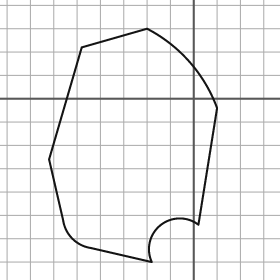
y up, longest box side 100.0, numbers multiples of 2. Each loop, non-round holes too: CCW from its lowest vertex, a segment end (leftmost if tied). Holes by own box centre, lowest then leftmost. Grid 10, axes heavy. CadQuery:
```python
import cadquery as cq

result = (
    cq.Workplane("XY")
    .moveTo(-18.0, -70.0)
    .threePointArc((-14.0, -54.0), (2.0, -54.0))
    .lineTo(10.0, -4.0)
    .threePointArc((-2.0, 16.0), (-20.0, 30.0))
    .lineTo(-48.0, 22.0)
    .lineTo(-62.0, -26.0)
    .lineTo(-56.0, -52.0)
    .threePointArc((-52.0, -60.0), (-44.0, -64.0))
    .close()
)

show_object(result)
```